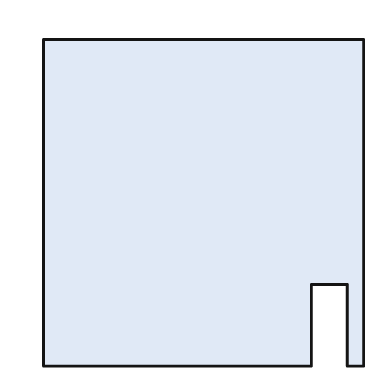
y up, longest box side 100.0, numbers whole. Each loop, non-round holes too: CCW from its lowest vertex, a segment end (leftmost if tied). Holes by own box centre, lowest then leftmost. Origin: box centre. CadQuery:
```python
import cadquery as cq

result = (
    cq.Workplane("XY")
    .moveTo(-49.0, -50.0)
    .lineTo(33.0, -50.0)
    .lineTo(33.0, -25.0)
    .lineTo(44.0, -25.0)
    .lineTo(44.0, -50.0)
    .lineTo(49.0, -50.0)
    .lineTo(49.0, 50.0)
    .lineTo(-49.0, 50.0)
    .close()
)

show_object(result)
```